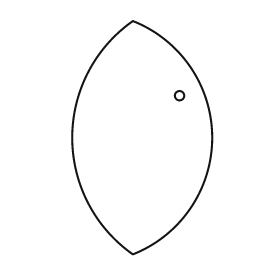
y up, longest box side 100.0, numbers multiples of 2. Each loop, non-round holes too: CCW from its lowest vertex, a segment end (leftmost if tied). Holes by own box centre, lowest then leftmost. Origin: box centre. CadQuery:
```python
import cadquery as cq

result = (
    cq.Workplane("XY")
    .moveTo(-4.0, -50.0)
    .threePointArc((30.0, 0.0), (-4.0, 50.0))
    .threePointArc((-30.0, 0.0), (-4.0, -50.0))
    .close()
    .moveTo(16.0, 18.0)
    .circle(2.0)
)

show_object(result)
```